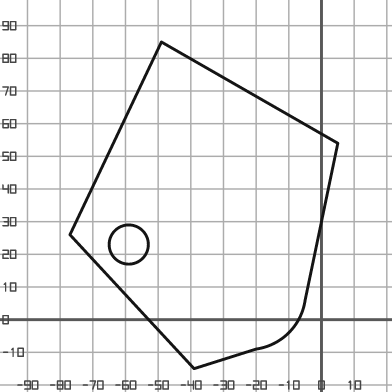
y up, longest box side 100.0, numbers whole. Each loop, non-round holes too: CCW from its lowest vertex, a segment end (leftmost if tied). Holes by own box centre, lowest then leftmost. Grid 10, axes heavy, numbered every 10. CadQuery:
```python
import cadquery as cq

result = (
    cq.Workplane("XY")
    .moveTo(-39.0, -15.0)
    .lineTo(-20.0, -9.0)
    .threePointArc((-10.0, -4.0), (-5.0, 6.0))
    .lineTo(5.0, 54.0)
    .lineTo(-49.0, 85.0)
    .lineTo(-77.0, 26.0)
    .close()
    .moveTo(-59.0, 23.0)
    .circle(6.0)
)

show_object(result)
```